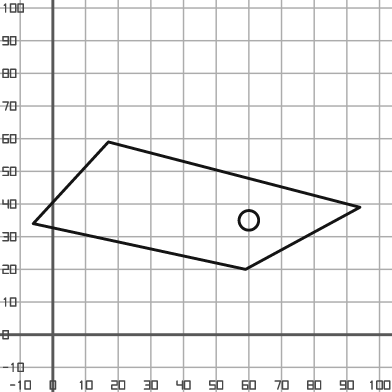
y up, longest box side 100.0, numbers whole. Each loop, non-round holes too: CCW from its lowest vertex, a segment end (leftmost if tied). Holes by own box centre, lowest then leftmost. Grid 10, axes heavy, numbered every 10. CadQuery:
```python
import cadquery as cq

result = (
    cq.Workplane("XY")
    .moveTo(59.0, 20.0)
    .lineTo(94.0, 39.0)
    .lineTo(17.0, 59.0)
    .lineTo(-6.0, 34.0)
    .close()
    .moveTo(60.0, 35.0)
    .circle(3.0)
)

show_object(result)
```